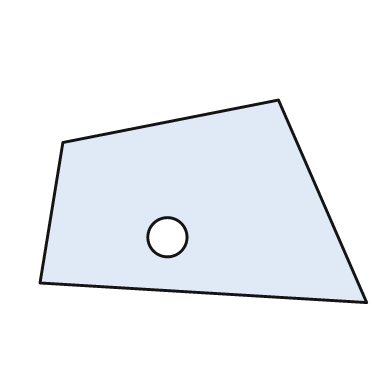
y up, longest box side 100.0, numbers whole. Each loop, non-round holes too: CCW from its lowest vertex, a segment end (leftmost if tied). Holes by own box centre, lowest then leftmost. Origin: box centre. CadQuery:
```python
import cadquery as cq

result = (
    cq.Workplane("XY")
    .moveTo(50.0, -31.0)
    .lineTo(23.0, 31.0)
    .lineTo(-43.0, 18.0)
    .lineTo(-50.0, -25.0)
    .close()
    .moveTo(-11.0, -11.0)
    .circle(6.0)
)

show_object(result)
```